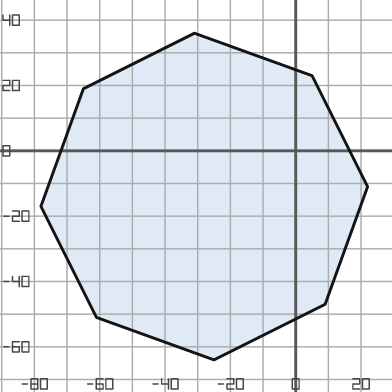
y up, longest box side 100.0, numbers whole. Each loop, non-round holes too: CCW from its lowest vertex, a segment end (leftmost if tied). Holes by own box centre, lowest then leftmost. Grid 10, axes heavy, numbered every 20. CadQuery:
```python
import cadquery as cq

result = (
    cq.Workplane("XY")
    .moveTo(-25.0, -64.0)
    .lineTo(9.0, -47.0)
    .lineTo(22.0, -11.0)
    .lineTo(5.0, 23.0)
    .lineTo(-31.0, 36.0)
    .lineTo(-65.0, 19.0)
    .lineTo(-78.0, -17.0)
    .lineTo(-61.0, -51.0)
    .close()
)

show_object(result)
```